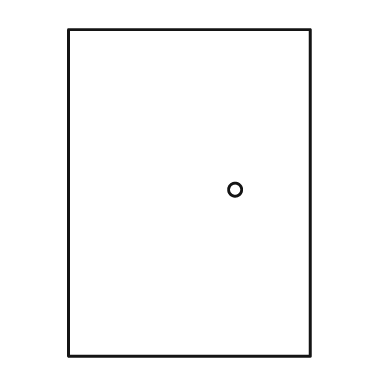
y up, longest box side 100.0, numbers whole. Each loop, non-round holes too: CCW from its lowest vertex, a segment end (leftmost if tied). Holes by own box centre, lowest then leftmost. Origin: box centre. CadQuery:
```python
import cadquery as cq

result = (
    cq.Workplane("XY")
    .moveTo(-37.0, -50.0)
    .lineTo(37.0, -50.0)
    .lineTo(37.0, 50.0)
    .lineTo(-37.0, 50.0)
    .close()
    .moveTo(14.0, 1.0)
    .circle(2.0)
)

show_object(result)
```